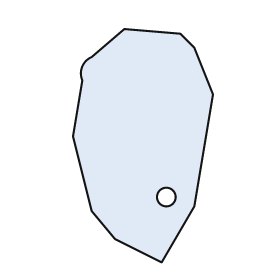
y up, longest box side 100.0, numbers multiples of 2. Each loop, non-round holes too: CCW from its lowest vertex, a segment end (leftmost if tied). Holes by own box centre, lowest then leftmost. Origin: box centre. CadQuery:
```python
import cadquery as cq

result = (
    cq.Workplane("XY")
    .moveTo(8.0, -50.0)
    .lineTo(22.0, -26.0)
    .lineTo(30.0, 22.0)
    .lineTo(22.0, 42.0)
    .lineTo(16.0, 48.0)
    .lineTo(-8.0, 50.0)
    .lineTo(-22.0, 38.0)
    .threePointArc((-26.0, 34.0), (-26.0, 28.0))
    .lineTo(-30.0, 4.0)
    .lineTo(-22.0, -28.0)
    .lineTo(-12.0, -40.0)
    .close()
    .moveTo(10.0, -22.0)
    .circle(4.0)
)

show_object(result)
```